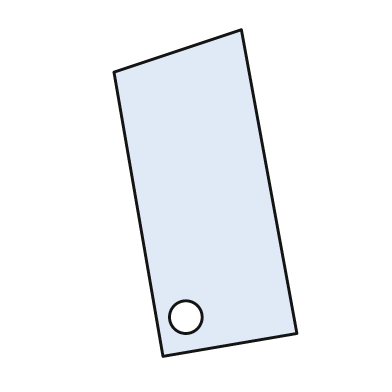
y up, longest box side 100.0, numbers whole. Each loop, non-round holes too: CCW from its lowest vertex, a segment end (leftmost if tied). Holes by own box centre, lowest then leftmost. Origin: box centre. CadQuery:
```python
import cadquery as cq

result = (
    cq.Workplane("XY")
    .moveTo(-13.0, -50.0)
    .lineTo(28.0, -43.0)
    .lineTo(11.0, 50.0)
    .lineTo(-28.0, 37.0)
    .close()
    .moveTo(-6.0, -38.0)
    .circle(5.0)
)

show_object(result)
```